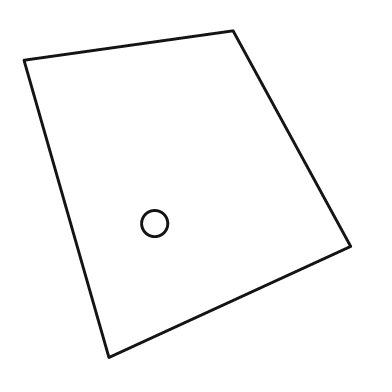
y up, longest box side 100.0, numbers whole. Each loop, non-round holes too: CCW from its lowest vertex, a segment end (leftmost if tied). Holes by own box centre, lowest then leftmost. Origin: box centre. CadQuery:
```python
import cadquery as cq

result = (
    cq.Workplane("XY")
    .moveTo(-24.0, -50.0)
    .lineTo(50.0, -16.0)
    .lineTo(14.0, 50.0)
    .lineTo(-50.0, 41.0)
    .close()
    .moveTo(-10.0, -9.0)
    .circle(4.0)
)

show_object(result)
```